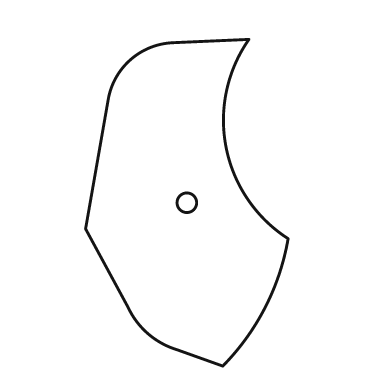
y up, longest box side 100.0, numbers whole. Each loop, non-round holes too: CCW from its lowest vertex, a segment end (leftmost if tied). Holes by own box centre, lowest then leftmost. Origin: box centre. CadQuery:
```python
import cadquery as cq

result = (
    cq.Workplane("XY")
    .moveTo(11.0, -50.0)
    .threePointArc((24.0, -32.0), (31.0, -11.0))
    .threePointArc((12.0, 17.0), (19.0, 50.0))
    .lineTo(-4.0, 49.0)
    .threePointArc((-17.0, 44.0), (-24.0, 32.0))
    .lineTo(-31.0, -8.0)
    .lineTo(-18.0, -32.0)
    .threePointArc((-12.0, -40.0), (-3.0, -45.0))
    .close()
    .moveTo(0.0, 0.0)
    .circle(3.0)
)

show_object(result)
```